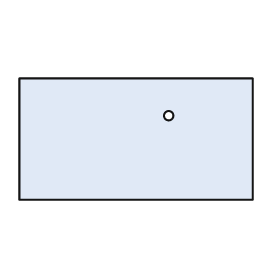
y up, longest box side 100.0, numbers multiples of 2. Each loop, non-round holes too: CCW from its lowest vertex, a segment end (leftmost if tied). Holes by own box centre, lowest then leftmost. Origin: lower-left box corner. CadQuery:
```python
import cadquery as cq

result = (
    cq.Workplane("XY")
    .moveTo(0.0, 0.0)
    .lineTo(100.0, 0.0)
    .lineTo(100.0, 52.0)
    .lineTo(0.0, 52.0)
    .close()
    .moveTo(64.0, 36.0)
    .circle(2.0)
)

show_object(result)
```